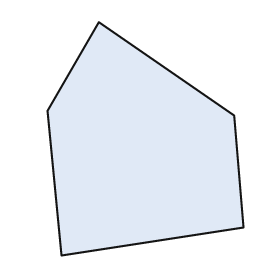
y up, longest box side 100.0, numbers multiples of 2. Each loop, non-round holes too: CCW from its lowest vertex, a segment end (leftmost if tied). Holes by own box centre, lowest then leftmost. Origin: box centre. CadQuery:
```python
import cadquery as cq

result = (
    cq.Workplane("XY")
    .moveTo(-36.0, -50.0)
    .lineTo(42.0, -38.0)
    .lineTo(38.0, 10.0)
    .lineTo(-20.0, 50.0)
    .lineTo(-42.0, 12.0)
    .close()
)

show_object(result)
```